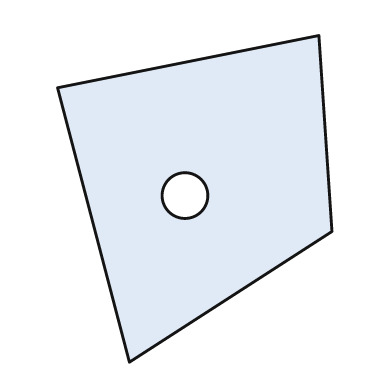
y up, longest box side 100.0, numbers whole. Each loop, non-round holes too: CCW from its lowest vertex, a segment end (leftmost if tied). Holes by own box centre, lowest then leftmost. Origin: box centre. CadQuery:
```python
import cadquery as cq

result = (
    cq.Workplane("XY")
    .moveTo(-20.0, -50.0)
    .lineTo(42.0, -10.0)
    .lineTo(38.0, 50.0)
    .lineTo(-42.0, 34.0)
    .close()
    .moveTo(-3.0, 1.0)
    .circle(7.0)
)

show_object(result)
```